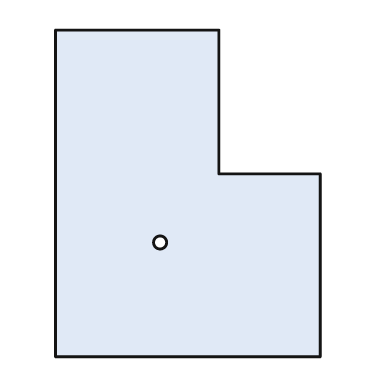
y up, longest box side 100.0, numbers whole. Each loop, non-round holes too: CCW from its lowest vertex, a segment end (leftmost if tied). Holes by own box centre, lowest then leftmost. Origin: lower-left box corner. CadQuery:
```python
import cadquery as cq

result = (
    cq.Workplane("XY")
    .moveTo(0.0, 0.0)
    .lineTo(81.0, 0.0)
    .lineTo(81.0, 56.0)
    .lineTo(50.0, 56.0)
    .lineTo(50.0, 100.0)
    .lineTo(0.0, 100.0)
    .close()
    .moveTo(32.0, 35.0)
    .circle(2.0)
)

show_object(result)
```